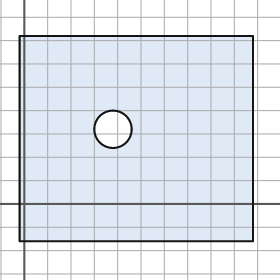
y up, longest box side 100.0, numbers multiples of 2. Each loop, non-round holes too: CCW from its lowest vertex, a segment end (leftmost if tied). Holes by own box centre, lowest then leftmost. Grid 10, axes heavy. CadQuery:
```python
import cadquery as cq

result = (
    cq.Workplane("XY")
    .moveTo(-2.0, -16.0)
    .lineTo(98.0, -16.0)
    .lineTo(98.0, 72.0)
    .lineTo(-2.0, 72.0)
    .close()
    .moveTo(38.0, 32.0)
    .circle(8.0)
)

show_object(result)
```